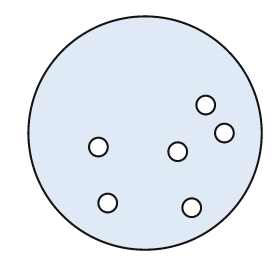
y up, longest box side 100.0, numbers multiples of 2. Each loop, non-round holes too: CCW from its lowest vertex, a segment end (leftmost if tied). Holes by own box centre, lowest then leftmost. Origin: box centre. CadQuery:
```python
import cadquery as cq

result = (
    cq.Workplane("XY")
    .moveTo(0.0, 0.0)
    .circle(50.0)
    .moveTo(20.0, -32.0)
    .circle(4.0)
    .moveTo(-16.0, -30.0)
    .circle(4.0)
    .moveTo(14.0, -8.0)
    .circle(4.0)
    .moveTo(-20.0, -6.0)
    .circle(4.0)
    .moveTo(34.0, 0.0)
    .circle(4.0)
    .moveTo(26.0, 12.0)
    .circle(4.0)
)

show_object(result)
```